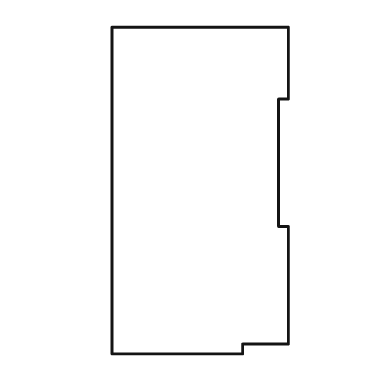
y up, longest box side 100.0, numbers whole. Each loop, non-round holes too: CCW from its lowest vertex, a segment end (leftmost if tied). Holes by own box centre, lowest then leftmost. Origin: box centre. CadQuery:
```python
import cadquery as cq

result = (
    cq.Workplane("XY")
    .moveTo(-27.0, -50.0)
    .lineTo(13.0, -50.0)
    .lineTo(13.0, -47.0)
    .lineTo(27.0, -47.0)
    .lineTo(27.0, -11.0)
    .lineTo(24.0, -11.0)
    .lineTo(24.0, 28.0)
    .lineTo(27.0, 28.0)
    .lineTo(27.0, 50.0)
    .lineTo(-27.0, 50.0)
    .close()
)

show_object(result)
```